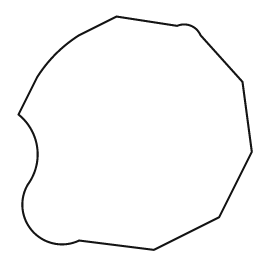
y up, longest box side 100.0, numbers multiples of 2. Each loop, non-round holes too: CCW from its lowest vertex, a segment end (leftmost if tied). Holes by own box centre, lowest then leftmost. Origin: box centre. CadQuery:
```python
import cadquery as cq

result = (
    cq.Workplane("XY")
    .moveTo(8.0, -50.0)
    .lineTo(36.0, -36.0)
    .lineTo(50.0, -8.0)
    .lineTo(46.0, 22.0)
    .lineTo(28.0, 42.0)
    .threePointArc((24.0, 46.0), (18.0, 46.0))
    .lineTo(-8.0, 50.0)
    .lineTo(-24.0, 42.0)
    .threePointArc((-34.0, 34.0), (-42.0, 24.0))
    .lineTo(-50.0, 8.0)
    .threePointArc((-42.0, -6.0), (-46.0, -22.0))
    .threePointArc((-44.0, -42.0), (-24.0, -46.0))
    .close()
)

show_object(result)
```